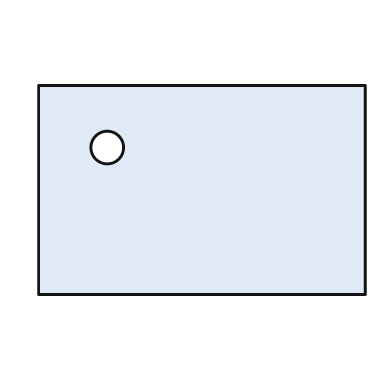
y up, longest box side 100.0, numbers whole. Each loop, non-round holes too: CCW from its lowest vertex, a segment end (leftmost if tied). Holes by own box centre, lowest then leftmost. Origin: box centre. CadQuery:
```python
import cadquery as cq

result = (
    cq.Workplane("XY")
    .moveTo(-50.0, -32.0)
    .lineTo(50.0, -32.0)
    .lineTo(50.0, 32.0)
    .lineTo(-50.0, 32.0)
    .close()
    .moveTo(-29.0, 13.0)
    .circle(5.0)
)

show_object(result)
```